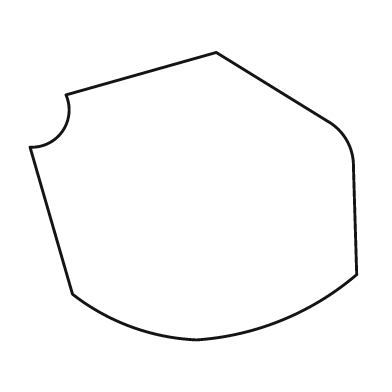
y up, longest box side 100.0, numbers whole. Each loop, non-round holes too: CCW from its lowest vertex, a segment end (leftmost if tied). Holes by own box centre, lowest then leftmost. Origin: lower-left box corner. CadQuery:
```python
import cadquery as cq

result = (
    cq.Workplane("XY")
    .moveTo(51.0, 0.0)
    .threePointArc((77.0, 6.0), (100.0, 20.0))
    .lineTo(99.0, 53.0)
    .threePointArc((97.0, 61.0), (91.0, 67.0))
    .lineTo(57.0, 88.0)
    .lineTo(11.0, 75.0)
    .threePointArc((10.0, 64.0), (0.0, 59.0))
    .lineTo(13.0, 14.0)
    .threePointArc((31.0, 4.0), (51.0, 0.0))
    .close()
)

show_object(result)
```